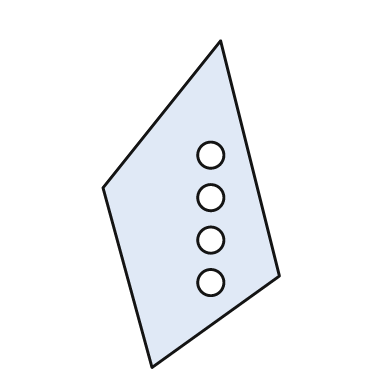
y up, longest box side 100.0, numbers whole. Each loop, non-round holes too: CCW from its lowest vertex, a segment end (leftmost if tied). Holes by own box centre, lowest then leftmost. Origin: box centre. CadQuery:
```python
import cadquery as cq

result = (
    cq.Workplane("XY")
    .moveTo(-12.0, -50.0)
    .lineTo(27.0, -22.0)
    .lineTo(9.0, 50.0)
    .lineTo(-27.0, 5.0)
    .close()
    .moveTo(6.0, -24.0)
    .circle(4.0)
    .moveTo(6.0, -11.0)
    .circle(4.0)
    .moveTo(6.0, 2.0)
    .circle(4.0)
    .moveTo(6.0, 15.0)
    .circle(4.0)
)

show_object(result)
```